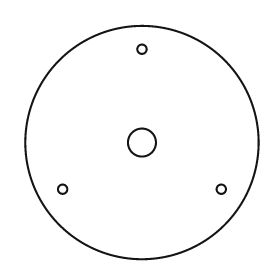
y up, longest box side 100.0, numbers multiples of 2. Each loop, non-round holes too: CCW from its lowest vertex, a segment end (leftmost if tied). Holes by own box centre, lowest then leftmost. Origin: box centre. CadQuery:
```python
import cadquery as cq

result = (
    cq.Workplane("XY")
    .moveTo(0.0, 0.0)
    .circle(50.0)
    .moveTo(-34.0, -20.0)
    .circle(2.0)
    .moveTo(34.0, -20.0)
    .circle(2.0)
    .moveTo(0.0, 0.0)
    .circle(6.0)
    .moveTo(0.0, 40.0)
    .circle(2.0)
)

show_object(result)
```